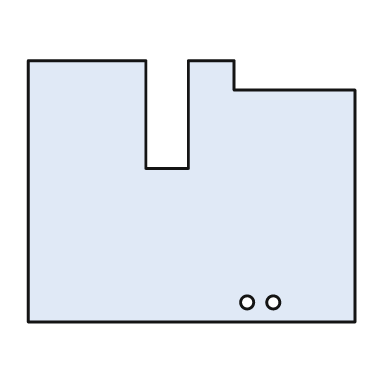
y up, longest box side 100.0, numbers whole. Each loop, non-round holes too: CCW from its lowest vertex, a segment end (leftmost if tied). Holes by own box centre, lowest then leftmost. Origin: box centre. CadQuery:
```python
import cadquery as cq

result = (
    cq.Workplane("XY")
    .moveTo(-50.0, -40.0)
    .lineTo(50.0, -40.0)
    .lineTo(50.0, 31.0)
    .lineTo(13.0, 31.0)
    .lineTo(13.0, 40.0)
    .lineTo(-1.0, 40.0)
    .lineTo(-1.0, 7.0)
    .lineTo(-14.0, 7.0)
    .lineTo(-14.0, 40.0)
    .lineTo(-50.0, 40.0)
    .close()
    .moveTo(17.0, -34.0)
    .circle(2.0)
    .moveTo(25.0, -34.0)
    .circle(2.0)
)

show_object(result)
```